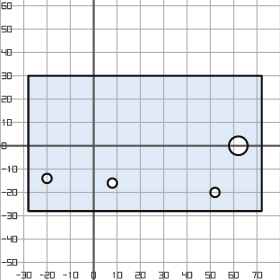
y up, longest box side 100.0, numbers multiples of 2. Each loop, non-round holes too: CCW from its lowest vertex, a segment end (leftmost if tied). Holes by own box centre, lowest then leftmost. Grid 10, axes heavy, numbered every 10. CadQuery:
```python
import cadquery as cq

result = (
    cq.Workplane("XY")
    .moveTo(-28.0, -28.0)
    .lineTo(72.0, -28.0)
    .lineTo(72.0, 30.0)
    .lineTo(-28.0, 30.0)
    .close()
    .moveTo(52.0, -20.0)
    .circle(2.0)
    .moveTo(8.0, -16.0)
    .circle(2.0)
    .moveTo(-20.0, -14.0)
    .circle(2.0)
    .moveTo(62.0, 0.0)
    .circle(4.0)
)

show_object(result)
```